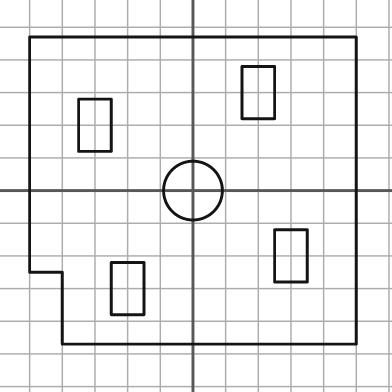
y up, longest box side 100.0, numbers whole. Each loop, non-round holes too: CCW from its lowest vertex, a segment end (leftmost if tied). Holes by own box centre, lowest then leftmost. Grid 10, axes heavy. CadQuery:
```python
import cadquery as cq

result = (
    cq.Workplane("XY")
    .moveTo(-40.0, -47.0)
    .lineTo(50.0, -47.0)
    .lineTo(50.0, 47.0)
    .lineTo(-50.0, 47.0)
    .lineTo(-50.0, -25.0)
    .lineTo(-40.0, -25.0)
    .close()
    .moveTo(-25.0, -38.0)
    .lineTo(-15.0, -38.0)
    .lineTo(-15.0, -22.0)
    .lineTo(-25.0, -22.0)
    .close()
    .moveTo(25.0, -28.0)
    .lineTo(35.0, -28.0)
    .lineTo(35.0, -12.0)
    .lineTo(25.0, -12.0)
    .close()
    .moveTo(0.0, 0.0)
    .circle(9.0)
    .moveTo(-35.0, 12.0)
    .lineTo(-25.0, 12.0)
    .lineTo(-25.0, 28.0)
    .lineTo(-35.0, 28.0)
    .close()
    .moveTo(15.0, 22.0)
    .lineTo(25.0, 22.0)
    .lineTo(25.0, 38.0)
    .lineTo(15.0, 38.0)
    .close()
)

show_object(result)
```